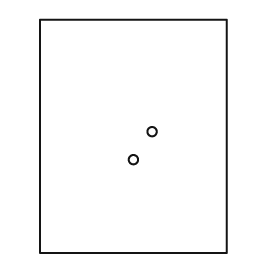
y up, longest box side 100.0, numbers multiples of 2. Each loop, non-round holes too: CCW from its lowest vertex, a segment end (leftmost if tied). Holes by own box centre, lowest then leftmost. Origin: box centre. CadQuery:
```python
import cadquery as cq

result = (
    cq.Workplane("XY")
    .moveTo(-40.0, -50.0)
    .lineTo(40.0, -50.0)
    .lineTo(40.0, 50.0)
    .lineTo(-40.0, 50.0)
    .close()
    .moveTo(0.0, -10.0)
    .circle(2.0)
    .moveTo(8.0, 2.0)
    .circle(2.0)
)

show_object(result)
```